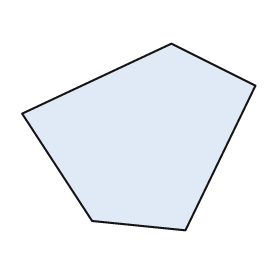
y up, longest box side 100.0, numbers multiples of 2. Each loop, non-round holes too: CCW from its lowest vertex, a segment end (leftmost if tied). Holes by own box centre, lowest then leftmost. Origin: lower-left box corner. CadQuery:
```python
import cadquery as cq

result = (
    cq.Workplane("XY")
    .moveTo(70.0, 0.0)
    .lineTo(100.0, 62.0)
    .lineTo(64.0, 80.0)
    .lineTo(0.0, 50.0)
    .lineTo(30.0, 4.0)
    .close()
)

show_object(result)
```